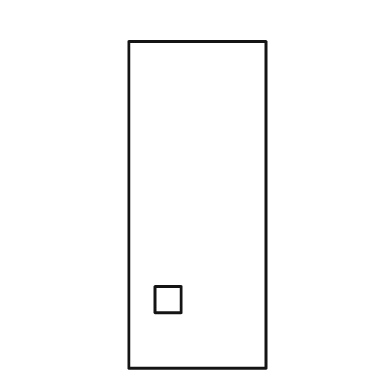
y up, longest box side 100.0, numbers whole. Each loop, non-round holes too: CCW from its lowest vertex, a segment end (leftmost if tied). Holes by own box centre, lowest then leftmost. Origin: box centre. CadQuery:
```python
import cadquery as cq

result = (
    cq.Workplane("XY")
    .moveTo(-21.0, -50.0)
    .lineTo(21.0, -50.0)
    .lineTo(21.0, 50.0)
    .lineTo(-21.0, 50.0)
    .close()
    .moveTo(-13.0, -33.0)
    .lineTo(-5.0, -33.0)
    .lineTo(-5.0, -25.0)
    .lineTo(-13.0, -25.0)
    .close()
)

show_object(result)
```